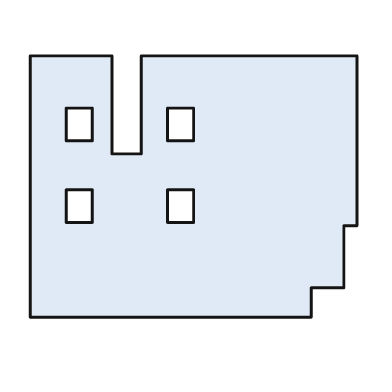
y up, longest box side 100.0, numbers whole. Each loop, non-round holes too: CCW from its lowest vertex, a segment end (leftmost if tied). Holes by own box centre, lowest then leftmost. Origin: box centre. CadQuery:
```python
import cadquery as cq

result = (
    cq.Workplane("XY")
    .moveTo(-50.0, -40.0)
    .lineTo(36.0, -40.0)
    .lineTo(36.0, -31.0)
    .lineTo(46.0, -31.0)
    .lineTo(46.0, -12.0)
    .lineTo(50.0, -12.0)
    .lineTo(50.0, 40.0)
    .lineTo(-16.0, 40.0)
    .lineTo(-16.0, 10.0)
    .lineTo(-25.0, 10.0)
    .lineTo(-25.0, 40.0)
    .lineTo(-50.0, 40.0)
    .close()
    .moveTo(-39.0, -11.0)
    .lineTo(-31.0, -11.0)
    .lineTo(-31.0, -1.0)
    .lineTo(-39.0, -1.0)
    .close()
    .moveTo(-8.0, -11.0)
    .lineTo(0.0, -11.0)
    .lineTo(0.0, -1.0)
    .lineTo(-8.0, -1.0)
    .close()
    .moveTo(-39.0, 14.0)
    .lineTo(-31.0, 14.0)
    .lineTo(-31.0, 24.0)
    .lineTo(-39.0, 24.0)
    .close()
    .moveTo(-8.0, 14.0)
    .lineTo(0.0, 14.0)
    .lineTo(0.0, 24.0)
    .lineTo(-8.0, 24.0)
    .close()
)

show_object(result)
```